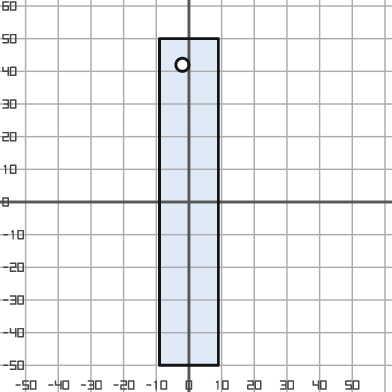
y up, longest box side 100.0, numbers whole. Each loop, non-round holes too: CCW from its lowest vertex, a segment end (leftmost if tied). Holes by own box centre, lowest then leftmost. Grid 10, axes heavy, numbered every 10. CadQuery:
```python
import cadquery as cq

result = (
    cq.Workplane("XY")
    .moveTo(-9.0, -50.0)
    .lineTo(9.0, -50.0)
    .lineTo(9.0, 50.0)
    .lineTo(-9.0, 50.0)
    .close()
    .moveTo(-2.0, 42.0)
    .circle(2.0)
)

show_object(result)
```